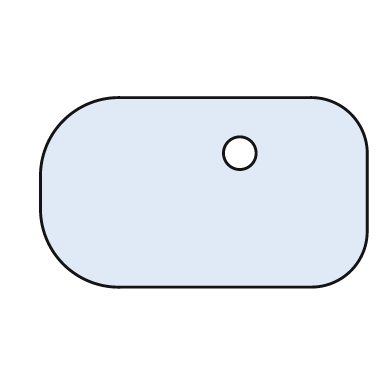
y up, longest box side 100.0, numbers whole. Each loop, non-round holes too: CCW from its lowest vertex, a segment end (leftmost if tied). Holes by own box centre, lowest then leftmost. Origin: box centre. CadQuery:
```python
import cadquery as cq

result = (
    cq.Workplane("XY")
    .moveTo(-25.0, -29.0)
    .lineTo(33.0, -29.0)
    .threePointArc((45.0, -24.0), (50.0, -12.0))
    .lineTo(50.0, 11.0)
    .threePointArc((45.0, 24.0), (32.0, 29.0))
    .lineTo(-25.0, 29.0)
    .threePointArc((-43.0, 22.0), (-50.0, 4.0))
    .lineTo(-50.0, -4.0)
    .threePointArc((-43.0, -22.0), (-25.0, -29.0))
    .close()
    .moveTo(11.0, 12.0)
    .circle(5.0)
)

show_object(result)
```